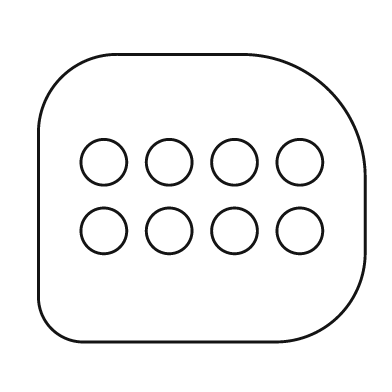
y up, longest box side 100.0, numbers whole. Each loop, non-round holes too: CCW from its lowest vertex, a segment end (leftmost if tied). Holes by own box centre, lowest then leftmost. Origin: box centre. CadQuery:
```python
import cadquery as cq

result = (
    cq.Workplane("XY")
    .moveTo(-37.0, -44.0)
    .lineTo(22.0, -44.0)
    .threePointArc((42.0, -36.0), (50.0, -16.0))
    .lineTo(50.0, 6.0)
    .threePointArc((39.0, 33.0), (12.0, 44.0))
    .lineTo(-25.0, 44.0)
    .threePointArc((-43.0, 37.0), (-50.0, 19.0))
    .lineTo(-50.0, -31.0)
    .threePointArc((-46.0, -40.0), (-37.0, -44.0))
    .close()
    .moveTo(-30.0, -10.0)
    .circle(7.0)
    .moveTo(-10.0, -10.0)
    .circle(7.0)
    .moveTo(10.0, -10.0)
    .circle(7.0)
    .moveTo(30.0, -10.0)
    .circle(7.0)
    .moveTo(-30.0, 11.0)
    .circle(7.0)
    .moveTo(-10.0, 11.0)
    .circle(7.0)
    .moveTo(10.0, 11.0)
    .circle(7.0)
    .moveTo(30.0, 11.0)
    .circle(7.0)
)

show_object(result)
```